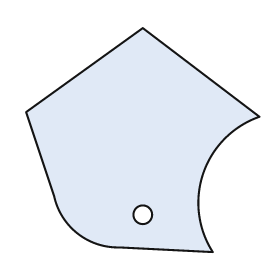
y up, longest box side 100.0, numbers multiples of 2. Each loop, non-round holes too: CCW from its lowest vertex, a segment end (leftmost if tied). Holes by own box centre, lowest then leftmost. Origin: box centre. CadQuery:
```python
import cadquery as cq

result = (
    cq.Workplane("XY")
    .moveTo(30.0, -48.0)
    .threePointArc((26.0, -14.0), (50.0, 10.0))
    .lineTo(0.0, 48.0)
    .lineTo(-50.0, 12.0)
    .lineTo(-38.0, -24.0)
    .threePointArc((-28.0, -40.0), (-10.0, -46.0))
    .close()
    .moveTo(0.0, -32.0)
    .circle(4.0)
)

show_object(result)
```